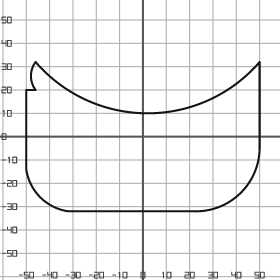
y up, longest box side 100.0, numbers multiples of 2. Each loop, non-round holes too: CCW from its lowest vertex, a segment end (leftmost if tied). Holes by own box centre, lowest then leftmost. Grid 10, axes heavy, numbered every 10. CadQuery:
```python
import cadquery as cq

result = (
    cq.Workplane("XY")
    .moveTo(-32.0, -32.0)
    .lineTo(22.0, -32.0)
    .threePointArc((42.0, -24.0), (50.0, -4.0))
    .lineTo(50.0, 32.0)
    .threePointArc((2.0, 10.0), (-46.0, 32.0))
    .threePointArc((-48.0, 26.0), (-46.0, 20.0))
    .lineTo(-50.0, 20.0)
    .lineTo(-50.0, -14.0)
    .threePointArc((-44.0, -26.0), (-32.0, -32.0))
    .close()
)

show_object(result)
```